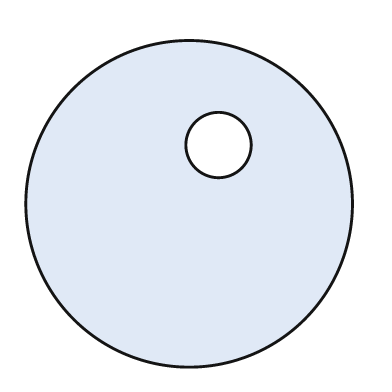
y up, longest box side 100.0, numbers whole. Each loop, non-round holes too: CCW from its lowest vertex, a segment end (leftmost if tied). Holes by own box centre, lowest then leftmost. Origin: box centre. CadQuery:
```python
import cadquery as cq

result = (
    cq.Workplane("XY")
    .moveTo(0.0, 0.0)
    .circle(50.0)
    .moveTo(9.0, 18.0)
    .circle(10.0)
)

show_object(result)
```